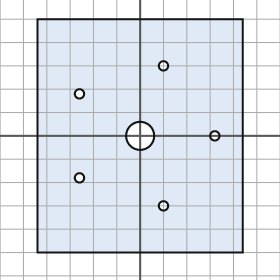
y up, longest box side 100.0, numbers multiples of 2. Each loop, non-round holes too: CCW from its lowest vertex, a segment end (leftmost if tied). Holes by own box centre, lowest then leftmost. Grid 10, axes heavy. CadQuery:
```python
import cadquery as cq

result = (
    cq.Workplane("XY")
    .moveTo(-44.0, -50.0)
    .lineTo(44.0, -50.0)
    .lineTo(44.0, 50.0)
    .lineTo(-44.0, 50.0)
    .close()
    .moveTo(10.0, -30.0)
    .circle(2.0)
    .moveTo(-26.0, -18.0)
    .circle(2.0)
    .moveTo(0.0, 0.0)
    .circle(6.0)
    .moveTo(32.0, 0.0)
    .circle(2.0)
    .moveTo(-26.0, 18.0)
    .circle(2.0)
    .moveTo(10.0, 30.0)
    .circle(2.0)
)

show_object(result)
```